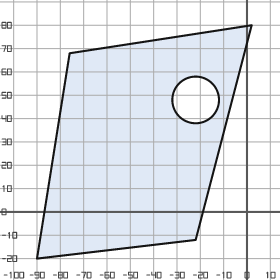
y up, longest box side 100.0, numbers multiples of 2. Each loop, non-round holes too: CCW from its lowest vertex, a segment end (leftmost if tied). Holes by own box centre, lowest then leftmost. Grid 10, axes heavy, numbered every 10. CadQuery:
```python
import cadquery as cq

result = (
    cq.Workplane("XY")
    .moveTo(-90.0, -20.0)
    .lineTo(-22.0, -12.0)
    .lineTo(2.0, 80.0)
    .lineTo(-76.0, 68.0)
    .close()
    .moveTo(-22.0, 48.0)
    .circle(10.0)
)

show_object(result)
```